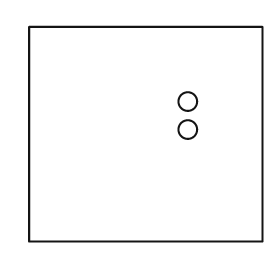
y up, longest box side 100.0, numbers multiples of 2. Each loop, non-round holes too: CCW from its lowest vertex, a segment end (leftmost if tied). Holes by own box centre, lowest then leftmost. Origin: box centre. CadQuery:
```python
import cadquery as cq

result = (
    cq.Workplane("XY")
    .moveTo(-50.0, -46.0)
    .lineTo(50.0, -46.0)
    .lineTo(50.0, 46.0)
    .lineTo(-50.0, 46.0)
    .close()
    .moveTo(18.0, 2.0)
    .circle(4.0)
    .moveTo(18.0, 14.0)
    .circle(4.0)
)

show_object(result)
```